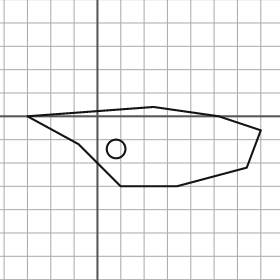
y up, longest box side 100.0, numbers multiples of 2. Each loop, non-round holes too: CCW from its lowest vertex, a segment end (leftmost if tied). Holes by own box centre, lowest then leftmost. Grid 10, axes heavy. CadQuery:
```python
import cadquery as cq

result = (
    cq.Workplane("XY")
    .moveTo(10.0, -30.0)
    .lineTo(34.0, -30.0)
    .lineTo(64.0, -22.0)
    .lineTo(70.0, -6.0)
    .lineTo(52.0, 0.0)
    .lineTo(24.0, 4.0)
    .lineTo(-30.0, 0.0)
    .lineTo(-8.0, -12.0)
    .close()
    .moveTo(8.0, -14.0)
    .circle(4.0)
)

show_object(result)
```